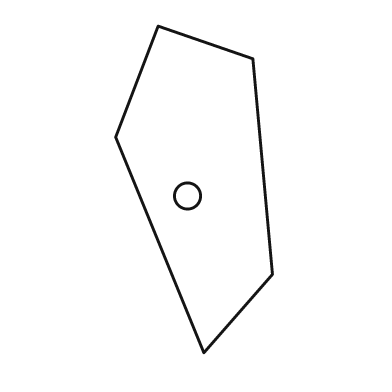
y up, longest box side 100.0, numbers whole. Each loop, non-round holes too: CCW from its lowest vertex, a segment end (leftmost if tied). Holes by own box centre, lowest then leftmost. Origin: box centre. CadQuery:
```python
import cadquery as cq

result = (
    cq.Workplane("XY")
    .moveTo(3.0, -50.0)
    .lineTo(24.0, -26.0)
    .lineTo(18.0, 40.0)
    .lineTo(-11.0, 50.0)
    .lineTo(-24.0, 16.0)
    .close()
    .moveTo(-2.0, -2.0)
    .circle(4.0)
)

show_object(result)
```